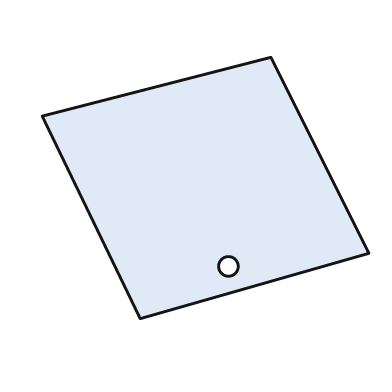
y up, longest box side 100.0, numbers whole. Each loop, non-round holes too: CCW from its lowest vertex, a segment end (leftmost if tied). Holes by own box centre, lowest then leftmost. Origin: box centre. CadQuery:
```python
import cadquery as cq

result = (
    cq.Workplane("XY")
    .moveTo(-20.0, -40.0)
    .lineTo(50.0, -20.0)
    .lineTo(20.0, 40.0)
    .lineTo(-50.0, 22.0)
    .close()
    .moveTo(7.0, -24.0)
    .circle(3.0)
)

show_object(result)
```